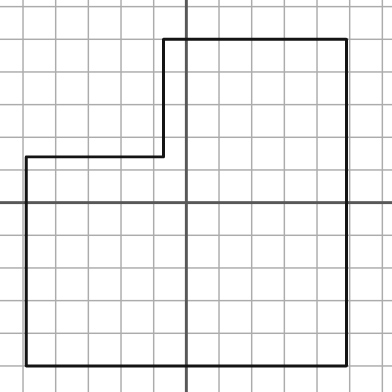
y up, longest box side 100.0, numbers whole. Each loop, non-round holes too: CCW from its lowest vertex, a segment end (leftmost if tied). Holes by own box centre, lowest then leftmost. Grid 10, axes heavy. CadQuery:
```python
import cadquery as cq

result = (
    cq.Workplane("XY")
    .moveTo(-49.0, -50.0)
    .lineTo(49.0, -50.0)
    .lineTo(49.0, 50.0)
    .lineTo(-7.0, 50.0)
    .lineTo(-7.0, 14.0)
    .lineTo(-49.0, 14.0)
    .close()
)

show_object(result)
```